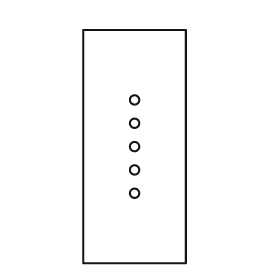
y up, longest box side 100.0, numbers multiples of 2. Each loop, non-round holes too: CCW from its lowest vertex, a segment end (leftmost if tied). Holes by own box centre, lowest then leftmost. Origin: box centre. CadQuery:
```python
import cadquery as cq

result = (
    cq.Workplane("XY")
    .moveTo(-22.0, -50.0)
    .lineTo(22.0, -50.0)
    .lineTo(22.0, 50.0)
    .lineTo(-22.0, 50.0)
    .close()
    .moveTo(0.0, -20.0)
    .circle(2.0)
    .moveTo(0.0, -10.0)
    .circle(2.0)
    .moveTo(0.0, 0.0)
    .circle(2.0)
    .moveTo(0.0, 10.0)
    .circle(2.0)
    .moveTo(0.0, 20.0)
    .circle(2.0)
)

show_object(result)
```